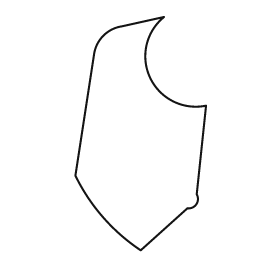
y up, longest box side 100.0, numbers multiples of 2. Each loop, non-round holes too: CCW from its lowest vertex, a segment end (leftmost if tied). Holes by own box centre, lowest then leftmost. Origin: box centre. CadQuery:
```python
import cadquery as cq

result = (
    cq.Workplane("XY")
    .moveTo(0.0, -50.0)
    .lineTo(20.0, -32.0)
    .threePointArc((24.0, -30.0), (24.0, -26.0))
    .lineTo(28.0, 12.0)
    .threePointArc((4.0, 24.0), (10.0, 50.0))
    .lineTo(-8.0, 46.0)
    .threePointArc((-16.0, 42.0), (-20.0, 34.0))
    .lineTo(-28.0, -18.0)
    .threePointArc((-16.0, -36.0), (0.0, -50.0))
    .close()
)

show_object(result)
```